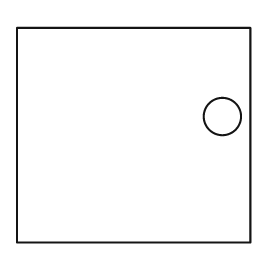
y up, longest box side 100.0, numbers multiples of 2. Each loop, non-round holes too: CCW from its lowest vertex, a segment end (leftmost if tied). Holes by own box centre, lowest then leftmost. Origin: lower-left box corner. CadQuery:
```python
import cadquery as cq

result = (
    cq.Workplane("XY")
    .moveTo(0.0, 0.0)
    .lineTo(100.0, 0.0)
    .lineTo(100.0, 92.0)
    .lineTo(0.0, 92.0)
    .close()
    .moveTo(88.0, 54.0)
    .circle(8.0)
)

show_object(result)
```